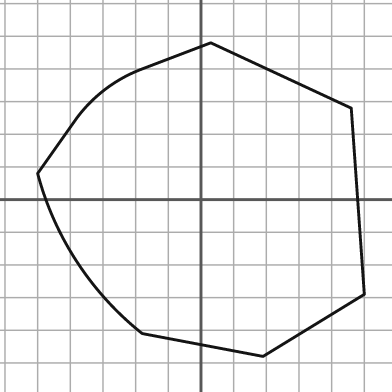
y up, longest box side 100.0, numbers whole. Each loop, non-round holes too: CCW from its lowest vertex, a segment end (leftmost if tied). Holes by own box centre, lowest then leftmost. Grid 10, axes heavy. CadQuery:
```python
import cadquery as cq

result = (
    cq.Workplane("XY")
    .moveTo(19.0, -48.0)
    .lineTo(50.0, -29.0)
    .lineTo(46.0, 28.0)
    .lineTo(3.0, 48.0)
    .lineTo(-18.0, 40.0)
    .threePointArc((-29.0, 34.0), (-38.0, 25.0))
    .lineTo(-50.0, 8.0)
    .threePointArc((-38.0, -19.0), (-18.0, -41.0))
    .close()
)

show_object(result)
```